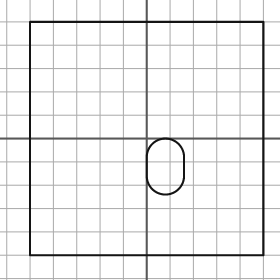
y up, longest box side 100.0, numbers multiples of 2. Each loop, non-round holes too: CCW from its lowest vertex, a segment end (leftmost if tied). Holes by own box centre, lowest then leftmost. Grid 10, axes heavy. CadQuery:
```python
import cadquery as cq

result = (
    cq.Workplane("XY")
    .moveTo(-50.0, -50.0)
    .lineTo(50.0, -50.0)
    .lineTo(50.0, 50.0)
    .lineTo(-50.0, 50.0)
    .close()
    .moveTo(0.0, -16.0)
    .threePointArc((8.0, -24.0), (16.0, -16.0))
    .lineTo(16.0, -8.0)
    .threePointArc((8.0, 0.0), (0.0, -8.0))
    .close()
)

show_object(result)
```